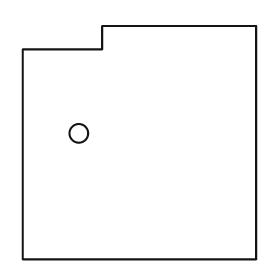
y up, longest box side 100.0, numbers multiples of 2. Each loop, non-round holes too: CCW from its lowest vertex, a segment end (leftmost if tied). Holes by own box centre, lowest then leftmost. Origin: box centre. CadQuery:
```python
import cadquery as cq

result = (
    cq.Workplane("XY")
    .moveTo(-50.0, -50.0)
    .lineTo(50.0, -50.0)
    .lineTo(50.0, 50.0)
    .lineTo(-16.0, 50.0)
    .lineTo(-16.0, 40.0)
    .lineTo(-50.0, 40.0)
    .close()
    .moveTo(-26.0, 4.0)
    .circle(4.0)
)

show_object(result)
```